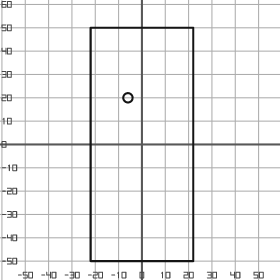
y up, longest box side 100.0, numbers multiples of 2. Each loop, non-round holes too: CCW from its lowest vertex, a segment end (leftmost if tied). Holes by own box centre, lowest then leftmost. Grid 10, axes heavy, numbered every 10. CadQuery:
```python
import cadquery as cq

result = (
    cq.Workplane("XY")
    .moveTo(-22.0, -50.0)
    .lineTo(22.0, -50.0)
    .lineTo(22.0, 50.0)
    .lineTo(-22.0, 50.0)
    .close()
    .moveTo(-6.0, 20.0)
    .circle(2.0)
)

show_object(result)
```